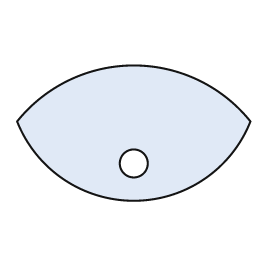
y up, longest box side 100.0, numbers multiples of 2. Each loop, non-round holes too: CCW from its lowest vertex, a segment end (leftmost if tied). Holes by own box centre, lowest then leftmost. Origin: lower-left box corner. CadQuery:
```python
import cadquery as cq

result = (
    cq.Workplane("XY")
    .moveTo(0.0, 34.0)
    .threePointArc((50.0, 0.0), (100.0, 34.0))
    .threePointArc((50.0, 58.0), (0.0, 34.0))
    .close()
    .moveTo(50.0, 16.0)
    .circle(6.0)
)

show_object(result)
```